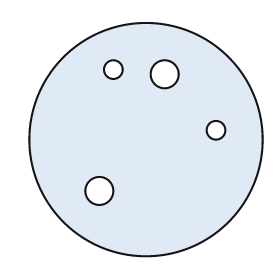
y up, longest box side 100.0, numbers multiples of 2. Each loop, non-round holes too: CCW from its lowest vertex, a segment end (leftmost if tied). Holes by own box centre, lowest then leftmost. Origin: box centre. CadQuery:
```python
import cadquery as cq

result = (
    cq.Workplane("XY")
    .moveTo(0.0, 0.0)
    .circle(50.0)
    .moveTo(-20.0, -22.0)
    .circle(6.0)
    .moveTo(30.0, 4.0)
    .circle(4.0)
    .moveTo(8.0, 28.0)
    .circle(6.0)
    .moveTo(-14.0, 30.0)
    .circle(4.0)
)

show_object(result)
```